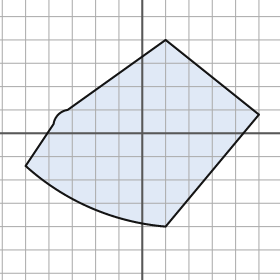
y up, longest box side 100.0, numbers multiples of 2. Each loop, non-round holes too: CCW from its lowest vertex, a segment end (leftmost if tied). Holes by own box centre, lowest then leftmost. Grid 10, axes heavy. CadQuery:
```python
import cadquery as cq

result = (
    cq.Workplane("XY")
    .moveTo(10.0, -40.0)
    .lineTo(50.0, 8.0)
    .lineTo(10.0, 40.0)
    .lineTo(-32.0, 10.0)
    .threePointArc((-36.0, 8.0), (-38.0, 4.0))
    .lineTo(-50.0, -14.0)
    .threePointArc((-22.0, -32.0), (10.0, -40.0))
    .close()
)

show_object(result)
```